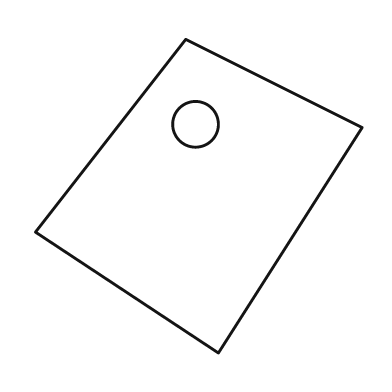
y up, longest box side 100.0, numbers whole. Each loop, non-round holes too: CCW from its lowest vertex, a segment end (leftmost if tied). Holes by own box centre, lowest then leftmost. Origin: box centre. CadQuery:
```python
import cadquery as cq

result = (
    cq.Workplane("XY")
    .moveTo(6.0, -48.0)
    .lineTo(50.0, 21.0)
    .lineTo(-4.0, 48.0)
    .lineTo(-50.0, -11.0)
    .close()
    .moveTo(-1.0, 22.0)
    .circle(7.0)
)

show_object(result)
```